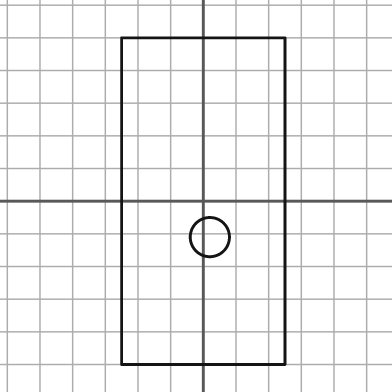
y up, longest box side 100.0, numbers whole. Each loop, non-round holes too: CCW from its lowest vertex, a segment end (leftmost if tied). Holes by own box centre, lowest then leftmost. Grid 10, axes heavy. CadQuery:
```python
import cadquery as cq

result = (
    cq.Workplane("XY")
    .moveTo(-25.0, -50.0)
    .lineTo(25.0, -50.0)
    .lineTo(25.0, 50.0)
    .lineTo(-25.0, 50.0)
    .close()
    .moveTo(2.0, -11.0)
    .circle(6.0)
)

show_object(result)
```